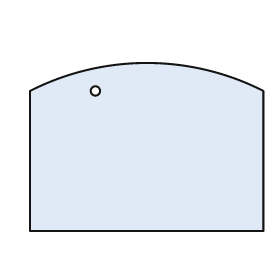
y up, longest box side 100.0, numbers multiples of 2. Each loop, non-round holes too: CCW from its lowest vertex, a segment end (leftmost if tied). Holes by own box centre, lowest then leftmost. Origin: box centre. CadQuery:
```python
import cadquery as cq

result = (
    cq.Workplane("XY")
    .moveTo(-50.0, -36.0)
    .lineTo(50.0, -36.0)
    .lineTo(50.0, 24.0)
    .threePointArc((0.0, 36.0), (-50.0, 24.0))
    .close()
    .moveTo(-22.0, 24.0)
    .circle(2.0)
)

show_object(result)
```